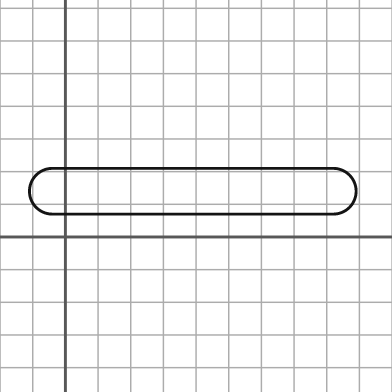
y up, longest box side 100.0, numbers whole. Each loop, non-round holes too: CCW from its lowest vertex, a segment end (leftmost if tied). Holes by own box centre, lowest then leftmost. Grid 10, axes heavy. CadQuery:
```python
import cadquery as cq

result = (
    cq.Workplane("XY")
    .moveTo(-4.0, 7.0)
    .lineTo(82.0, 7.0)
    .threePointArc((89.0, 14.0), (82.0, 21.0))
    .lineTo(-4.0, 21.0)
    .threePointArc((-11.0, 14.0), (-4.0, 7.0))
    .close()
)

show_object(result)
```